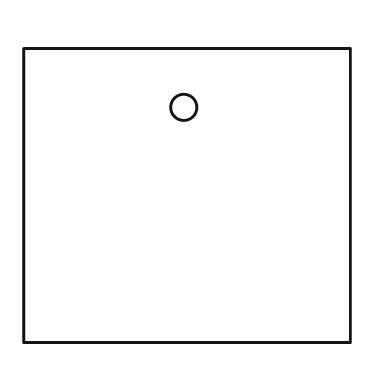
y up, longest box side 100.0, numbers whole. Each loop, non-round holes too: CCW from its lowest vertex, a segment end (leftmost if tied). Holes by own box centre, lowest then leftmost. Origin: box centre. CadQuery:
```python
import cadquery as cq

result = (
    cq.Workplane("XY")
    .moveTo(-50.0, -45.0)
    .lineTo(50.0, -45.0)
    .lineTo(50.0, 45.0)
    .lineTo(-50.0, 45.0)
    .close()
    .moveTo(-1.0, 27.0)
    .circle(4.0)
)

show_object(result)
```